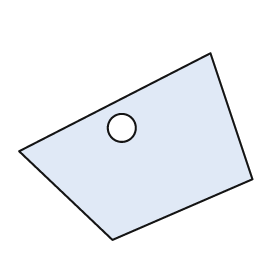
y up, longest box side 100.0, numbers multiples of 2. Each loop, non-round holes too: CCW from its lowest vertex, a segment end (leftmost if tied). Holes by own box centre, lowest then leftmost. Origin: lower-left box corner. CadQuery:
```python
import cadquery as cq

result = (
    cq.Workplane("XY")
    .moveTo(40.0, 0.0)
    .lineTo(100.0, 26.0)
    .lineTo(82.0, 80.0)
    .lineTo(0.0, 38.0)
    .close()
    .moveTo(44.0, 48.0)
    .circle(6.0)
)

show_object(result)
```